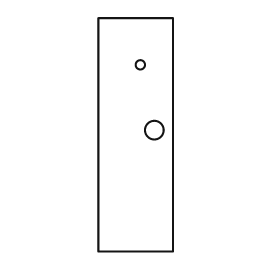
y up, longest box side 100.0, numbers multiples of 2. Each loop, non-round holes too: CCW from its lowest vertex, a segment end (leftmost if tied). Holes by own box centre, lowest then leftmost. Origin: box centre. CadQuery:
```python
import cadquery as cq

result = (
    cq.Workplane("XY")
    .moveTo(-16.0, -50.0)
    .lineTo(16.0, -50.0)
    .lineTo(16.0, 50.0)
    .lineTo(-16.0, 50.0)
    .close()
    .moveTo(8.0, 2.0)
    .circle(4.0)
    .moveTo(2.0, 30.0)
    .circle(2.0)
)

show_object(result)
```